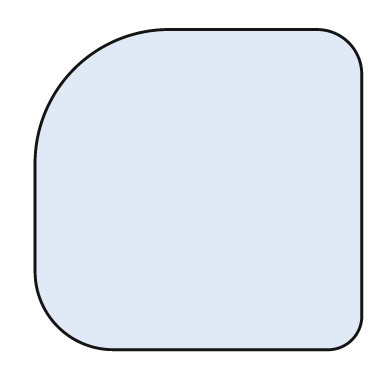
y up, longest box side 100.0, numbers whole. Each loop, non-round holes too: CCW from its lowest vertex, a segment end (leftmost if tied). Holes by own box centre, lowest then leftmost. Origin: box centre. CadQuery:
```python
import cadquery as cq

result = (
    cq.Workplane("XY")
    .moveTo(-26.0, -49.0)
    .lineTo(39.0, -49.0)
    .threePointArc((47.0, -46.0), (50.0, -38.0))
    .lineTo(50.0, 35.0)
    .threePointArc((46.0, 45.0), (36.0, 49.0))
    .lineTo(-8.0, 49.0)
    .threePointArc((-38.0, 37.0), (-50.0, 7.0))
    .lineTo(-50.0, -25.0)
    .threePointArc((-43.0, -42.0), (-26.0, -49.0))
    .close()
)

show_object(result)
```